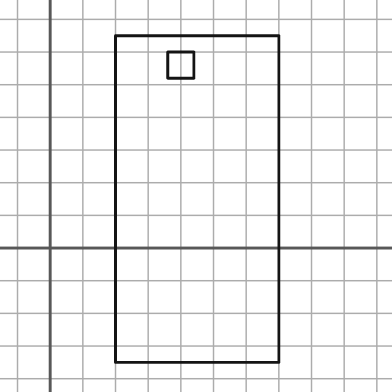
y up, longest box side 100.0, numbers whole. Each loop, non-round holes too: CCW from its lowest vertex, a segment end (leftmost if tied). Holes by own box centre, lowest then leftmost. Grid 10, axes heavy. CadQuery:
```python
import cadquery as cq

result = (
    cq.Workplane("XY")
    .moveTo(20.0, -35.0)
    .lineTo(70.0, -35.0)
    .lineTo(70.0, 65.0)
    .lineTo(20.0, 65.0)
    .close()
    .moveTo(36.0, 52.0)
    .lineTo(44.0, 52.0)
    .lineTo(44.0, 60.0)
    .lineTo(36.0, 60.0)
    .close()
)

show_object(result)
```